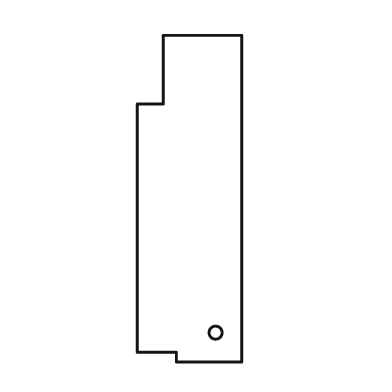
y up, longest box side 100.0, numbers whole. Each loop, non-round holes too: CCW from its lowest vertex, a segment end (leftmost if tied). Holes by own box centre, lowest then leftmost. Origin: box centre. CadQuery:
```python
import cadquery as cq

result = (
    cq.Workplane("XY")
    .moveTo(-4.0, -50.0)
    .lineTo(16.0, -50.0)
    .lineTo(16.0, 50.0)
    .lineTo(-8.0, 50.0)
    .lineTo(-8.0, 29.0)
    .lineTo(-16.0, 29.0)
    .lineTo(-16.0, -47.0)
    .lineTo(-4.0, -47.0)
    .close()
    .moveTo(8.0, -41.0)
    .circle(2.0)
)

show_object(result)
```